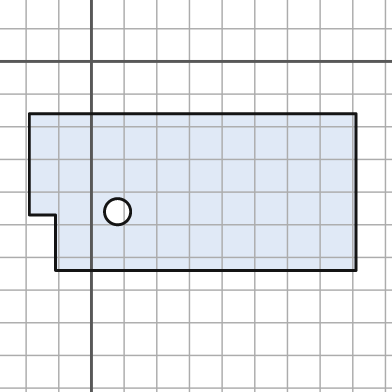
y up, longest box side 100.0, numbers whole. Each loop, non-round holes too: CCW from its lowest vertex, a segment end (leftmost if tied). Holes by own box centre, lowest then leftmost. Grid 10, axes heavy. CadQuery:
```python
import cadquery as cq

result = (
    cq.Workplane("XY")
    .moveTo(-11.0, -64.0)
    .lineTo(81.0, -64.0)
    .lineTo(81.0, -16.0)
    .lineTo(-19.0, -16.0)
    .lineTo(-19.0, -47.0)
    .lineTo(-11.0, -47.0)
    .close()
    .moveTo(8.0, -46.0)
    .circle(4.0)
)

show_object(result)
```